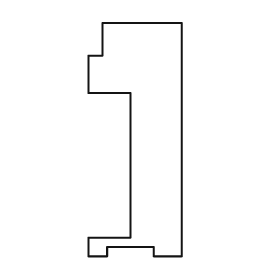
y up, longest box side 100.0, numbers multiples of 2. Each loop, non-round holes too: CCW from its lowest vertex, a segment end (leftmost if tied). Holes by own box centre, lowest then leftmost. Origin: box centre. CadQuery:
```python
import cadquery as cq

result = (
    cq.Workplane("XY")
    .moveTo(-20.0, -50.0)
    .lineTo(-12.0, -50.0)
    .lineTo(-12.0, -46.0)
    .lineTo(8.0, -46.0)
    .lineTo(8.0, -50.0)
    .lineTo(20.0, -50.0)
    .lineTo(20.0, 50.0)
    .lineTo(-14.0, 50.0)
    .lineTo(-14.0, 36.0)
    .lineTo(-20.0, 36.0)
    .lineTo(-20.0, 20.0)
    .lineTo(-2.0, 20.0)
    .lineTo(-2.0, -42.0)
    .lineTo(-20.0, -42.0)
    .close()
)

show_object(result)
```